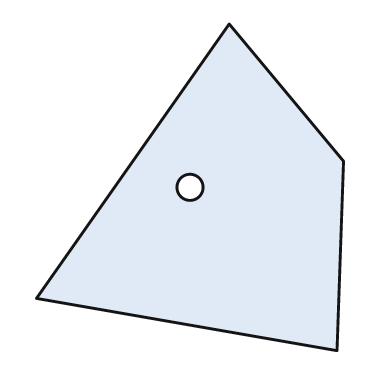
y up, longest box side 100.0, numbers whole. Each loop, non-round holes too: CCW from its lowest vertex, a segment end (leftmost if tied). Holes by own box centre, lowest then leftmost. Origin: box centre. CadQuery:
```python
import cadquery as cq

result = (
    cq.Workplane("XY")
    .moveTo(45.0, -50.0)
    .lineTo(47.0, 8.0)
    .lineTo(12.0, 50.0)
    .lineTo(-47.0, -34.0)
    .close()
    .moveTo(0.0, 0.0)
    .circle(4.0)
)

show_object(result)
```